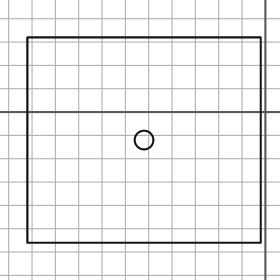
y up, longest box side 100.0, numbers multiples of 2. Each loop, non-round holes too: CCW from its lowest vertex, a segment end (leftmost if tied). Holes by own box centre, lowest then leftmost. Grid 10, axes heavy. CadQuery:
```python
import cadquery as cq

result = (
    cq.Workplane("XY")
    .moveTo(-102.0, -56.0)
    .lineTo(-2.0, -56.0)
    .lineTo(-2.0, 32.0)
    .lineTo(-102.0, 32.0)
    .close()
    .moveTo(-52.0, -12.0)
    .circle(4.0)
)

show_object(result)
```